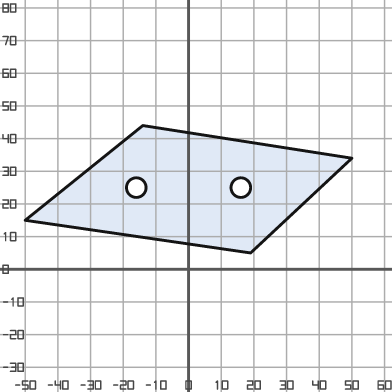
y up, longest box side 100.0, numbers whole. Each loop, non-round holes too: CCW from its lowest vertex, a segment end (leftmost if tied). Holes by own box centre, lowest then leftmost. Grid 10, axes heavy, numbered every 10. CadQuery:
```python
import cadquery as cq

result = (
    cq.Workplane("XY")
    .moveTo(19.0, 5.0)
    .lineTo(50.0, 34.0)
    .lineTo(-14.0, 44.0)
    .lineTo(-50.0, 15.0)
    .close()
    .moveTo(-16.0, 25.0)
    .circle(3.0)
    .moveTo(16.0, 25.0)
    .circle(3.0)
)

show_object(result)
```